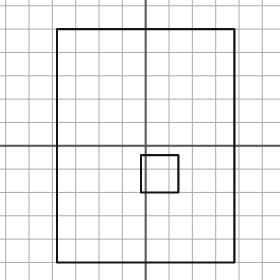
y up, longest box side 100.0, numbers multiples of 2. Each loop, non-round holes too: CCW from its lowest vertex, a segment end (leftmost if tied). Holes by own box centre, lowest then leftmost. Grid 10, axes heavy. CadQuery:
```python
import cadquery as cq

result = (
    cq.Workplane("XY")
    .moveTo(-38.0, -50.0)
    .lineTo(38.0, -50.0)
    .lineTo(38.0, 50.0)
    .lineTo(-38.0, 50.0)
    .close()
    .moveTo(-2.0, -20.0)
    .lineTo(14.0, -20.0)
    .lineTo(14.0, -4.0)
    .lineTo(-2.0, -4.0)
    .close()
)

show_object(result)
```